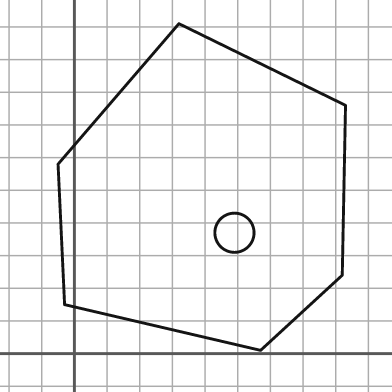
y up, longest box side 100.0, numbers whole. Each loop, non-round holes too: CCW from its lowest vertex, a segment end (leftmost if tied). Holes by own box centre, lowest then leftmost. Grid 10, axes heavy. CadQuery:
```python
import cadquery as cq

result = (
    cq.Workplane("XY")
    .moveTo(57.0, 1.0)
    .lineTo(82.0, 24.0)
    .lineTo(83.0, 76.0)
    .lineTo(32.0, 101.0)
    .lineTo(-5.0, 58.0)
    .lineTo(-3.0, 15.0)
    .close()
    .moveTo(49.0, 37.0)
    .circle(6.0)
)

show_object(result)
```